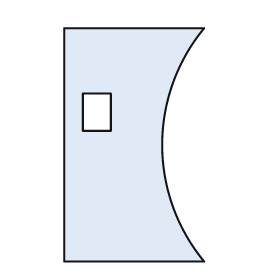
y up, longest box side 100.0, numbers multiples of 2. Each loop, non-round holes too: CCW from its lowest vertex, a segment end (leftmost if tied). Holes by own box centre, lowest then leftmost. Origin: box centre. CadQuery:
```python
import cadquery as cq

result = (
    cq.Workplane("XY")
    .moveTo(-30.0, -50.0)
    .lineTo(30.0, -50.0)
    .threePointArc((12.0, 0.0), (30.0, 50.0))
    .lineTo(-30.0, 50.0)
    .close()
    .moveTo(-22.0, 6.0)
    .lineTo(-10.0, 6.0)
    .lineTo(-10.0, 22.0)
    .lineTo(-22.0, 22.0)
    .close()
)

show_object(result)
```